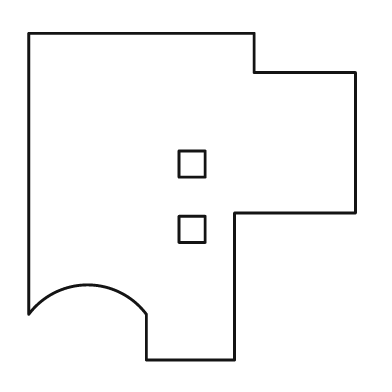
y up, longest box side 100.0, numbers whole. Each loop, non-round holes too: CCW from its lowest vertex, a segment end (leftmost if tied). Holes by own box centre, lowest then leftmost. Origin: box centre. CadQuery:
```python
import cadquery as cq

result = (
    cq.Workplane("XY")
    .moveTo(-14.0, -50.0)
    .lineTo(13.0, -50.0)
    .lineTo(13.0, -5.0)
    .lineTo(50.0, -5.0)
    .lineTo(50.0, 38.0)
    .lineTo(19.0, 38.0)
    .lineTo(19.0, 50.0)
    .lineTo(-50.0, 50.0)
    .lineTo(-50.0, -36.0)
    .threePointArc((-32.0, -27.0), (-14.0, -36.0))
    .close()
    .moveTo(-4.0, -14.0)
    .lineTo(4.0, -14.0)
    .lineTo(4.0, -6.0)
    .lineTo(-4.0, -6.0)
    .close()
    .moveTo(-4.0, 6.0)
    .lineTo(4.0, 6.0)
    .lineTo(4.0, 14.0)
    .lineTo(-4.0, 14.0)
    .close()
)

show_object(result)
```